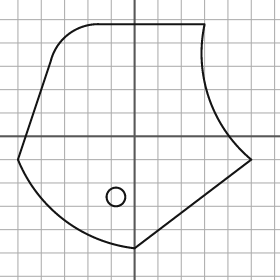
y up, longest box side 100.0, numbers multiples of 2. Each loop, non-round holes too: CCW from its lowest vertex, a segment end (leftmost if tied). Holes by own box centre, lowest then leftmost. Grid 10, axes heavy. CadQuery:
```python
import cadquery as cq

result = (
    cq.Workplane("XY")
    .moveTo(0.0, -48.0)
    .lineTo(50.0, -10.0)
    .threePointArc((32.0, 16.0), (30.0, 48.0))
    .lineTo(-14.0, 48.0)
    .threePointArc((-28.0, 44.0), (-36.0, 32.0))
    .lineTo(-50.0, -10.0)
    .threePointArc((-30.0, -36.0), (0.0, -48.0))
    .close()
    .moveTo(-8.0, -26.0)
    .circle(4.0)
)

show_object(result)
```